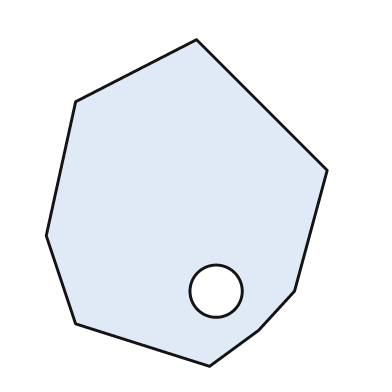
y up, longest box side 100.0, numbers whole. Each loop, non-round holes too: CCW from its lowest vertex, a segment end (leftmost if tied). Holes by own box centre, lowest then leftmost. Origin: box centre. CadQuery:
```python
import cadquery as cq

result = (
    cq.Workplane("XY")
    .moveTo(7.0, -50.0)
    .lineTo(22.0, -39.0)
    .lineTo(33.0, -27.0)
    .lineTo(43.0, 10.0)
    .lineTo(3.0, 50.0)
    .lineTo(-34.0, 31.0)
    .lineTo(-43.0, -10.0)
    .lineTo(-34.0, -37.0)
    .close()
    .moveTo(9.0, -27.0)
    .circle(8.0)
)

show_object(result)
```